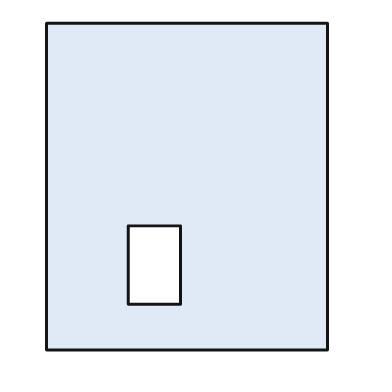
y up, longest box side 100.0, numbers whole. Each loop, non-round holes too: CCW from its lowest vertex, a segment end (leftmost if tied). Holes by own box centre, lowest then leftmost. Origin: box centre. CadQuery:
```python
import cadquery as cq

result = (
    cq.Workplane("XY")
    .moveTo(-43.0, -50.0)
    .lineTo(43.0, -50.0)
    .lineTo(43.0, 50.0)
    .lineTo(-43.0, 50.0)
    .close()
    .moveTo(-18.0, -36.0)
    .lineTo(-2.0, -36.0)
    .lineTo(-2.0, -12.0)
    .lineTo(-18.0, -12.0)
    .close()
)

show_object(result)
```